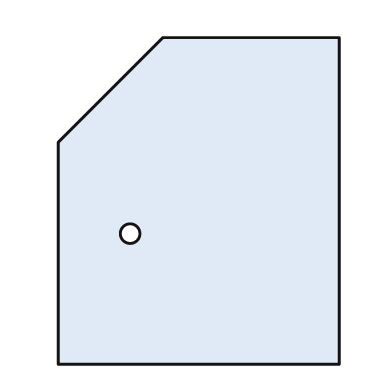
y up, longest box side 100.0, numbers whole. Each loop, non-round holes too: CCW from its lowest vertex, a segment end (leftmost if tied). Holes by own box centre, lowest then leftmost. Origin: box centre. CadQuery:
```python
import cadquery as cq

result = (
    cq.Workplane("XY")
    .moveTo(-43.0, -50.0)
    .lineTo(43.0, -50.0)
    .lineTo(43.0, 50.0)
    .lineTo(-11.0, 50.0)
    .lineTo(-43.0, 18.0)
    .close()
    .moveTo(-21.0, -10.0)
    .circle(3.0)
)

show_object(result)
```